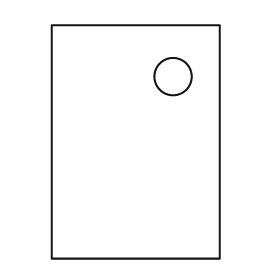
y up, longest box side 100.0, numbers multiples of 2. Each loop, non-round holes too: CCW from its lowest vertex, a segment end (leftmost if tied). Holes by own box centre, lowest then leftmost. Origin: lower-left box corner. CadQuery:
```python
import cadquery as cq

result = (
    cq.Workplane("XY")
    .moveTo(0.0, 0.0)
    .lineTo(72.0, 0.0)
    .lineTo(72.0, 100.0)
    .lineTo(0.0, 100.0)
    .close()
    .moveTo(52.0, 78.0)
    .circle(8.0)
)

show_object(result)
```